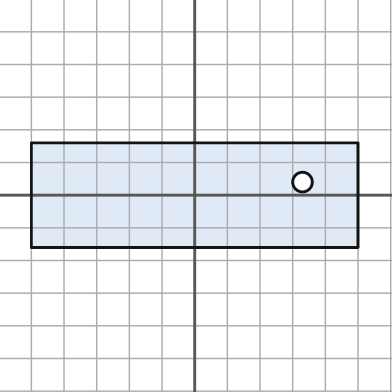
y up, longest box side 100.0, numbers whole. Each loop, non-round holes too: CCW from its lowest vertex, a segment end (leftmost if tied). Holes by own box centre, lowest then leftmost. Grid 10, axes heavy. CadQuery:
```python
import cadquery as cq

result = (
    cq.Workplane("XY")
    .moveTo(-50.0, -16.0)
    .lineTo(50.0, -16.0)
    .lineTo(50.0, 16.0)
    .lineTo(-50.0, 16.0)
    .close()
    .moveTo(33.0, 4.0)
    .circle(3.0)
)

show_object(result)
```